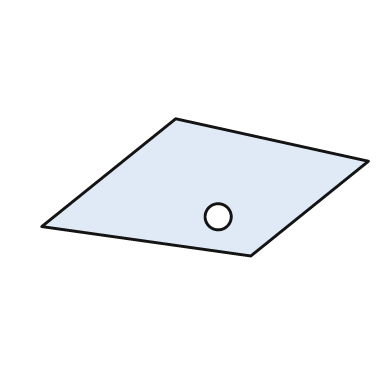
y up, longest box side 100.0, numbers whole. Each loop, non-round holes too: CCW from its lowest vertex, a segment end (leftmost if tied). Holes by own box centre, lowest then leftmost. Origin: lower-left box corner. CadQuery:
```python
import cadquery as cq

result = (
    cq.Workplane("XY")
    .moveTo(64.0, 0.0)
    .lineTo(100.0, 29.0)
    .lineTo(41.0, 42.0)
    .lineTo(0.0, 9.0)
    .close()
    .moveTo(54.0, 12.0)
    .circle(4.0)
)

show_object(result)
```